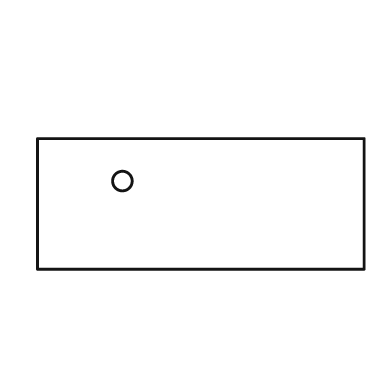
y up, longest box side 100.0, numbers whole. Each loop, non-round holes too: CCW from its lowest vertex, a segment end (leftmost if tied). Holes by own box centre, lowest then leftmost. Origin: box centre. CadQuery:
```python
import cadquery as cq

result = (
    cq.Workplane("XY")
    .moveTo(-50.0, -20.0)
    .lineTo(50.0, -20.0)
    .lineTo(50.0, 20.0)
    .lineTo(-50.0, 20.0)
    .close()
    .moveTo(-24.0, 7.0)
    .circle(3.0)
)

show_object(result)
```